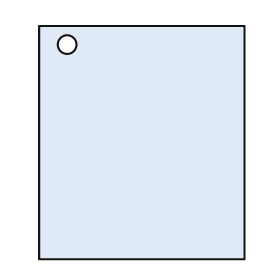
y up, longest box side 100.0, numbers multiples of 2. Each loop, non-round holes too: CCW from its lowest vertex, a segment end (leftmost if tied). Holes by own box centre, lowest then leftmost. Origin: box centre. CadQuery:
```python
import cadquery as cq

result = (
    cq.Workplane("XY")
    .moveTo(-44.0, -50.0)
    .lineTo(44.0, -50.0)
    .lineTo(44.0, 50.0)
    .lineTo(-44.0, 50.0)
    .close()
    .moveTo(-32.0, 42.0)
    .circle(4.0)
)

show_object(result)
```